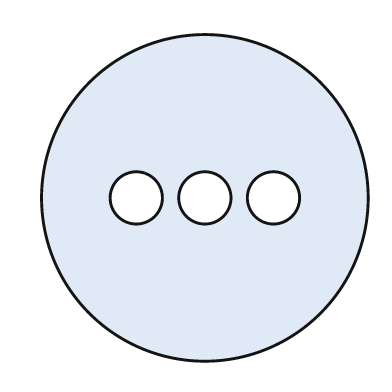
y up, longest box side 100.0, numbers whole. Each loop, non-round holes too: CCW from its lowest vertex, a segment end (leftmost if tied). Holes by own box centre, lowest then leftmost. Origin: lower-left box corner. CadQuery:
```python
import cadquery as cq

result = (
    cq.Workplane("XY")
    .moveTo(50.0, 50.0)
    .circle(50.0)
    .moveTo(29.0, 50.0)
    .circle(8.0)
    .moveTo(50.0, 50.0)
    .circle(8.0)
    .moveTo(71.0, 50.0)
    .circle(8.0)
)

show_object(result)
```